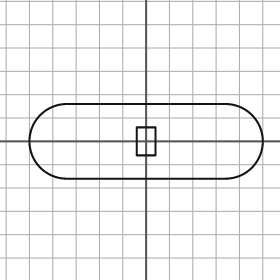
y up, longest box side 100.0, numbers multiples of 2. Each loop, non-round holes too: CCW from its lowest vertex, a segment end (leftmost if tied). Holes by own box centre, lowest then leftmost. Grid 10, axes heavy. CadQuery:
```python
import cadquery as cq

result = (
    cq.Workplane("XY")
    .moveTo(-34.0, -16.0)
    .lineTo(34.0, -16.0)
    .threePointArc((50.0, 0.0), (34.0, 16.0))
    .lineTo(-34.0, 16.0)
    .threePointArc((-50.0, 0.0), (-34.0, -16.0))
    .close()
    .moveTo(-4.0, -6.0)
    .lineTo(4.0, -6.0)
    .lineTo(4.0, 6.0)
    .lineTo(-4.0, 6.0)
    .close()
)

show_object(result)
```